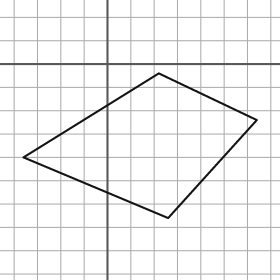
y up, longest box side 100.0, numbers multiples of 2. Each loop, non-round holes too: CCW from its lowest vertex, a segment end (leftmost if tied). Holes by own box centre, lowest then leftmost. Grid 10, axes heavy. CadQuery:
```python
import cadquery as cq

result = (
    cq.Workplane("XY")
    .moveTo(26.0, -66.0)
    .lineTo(64.0, -24.0)
    .lineTo(22.0, -4.0)
    .lineTo(-36.0, -40.0)
    .close()
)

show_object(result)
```